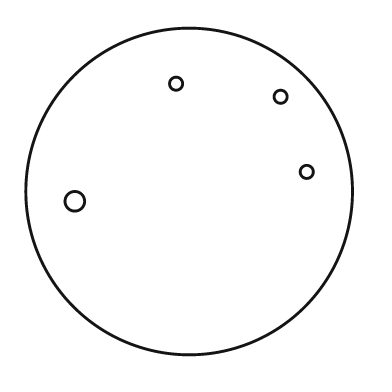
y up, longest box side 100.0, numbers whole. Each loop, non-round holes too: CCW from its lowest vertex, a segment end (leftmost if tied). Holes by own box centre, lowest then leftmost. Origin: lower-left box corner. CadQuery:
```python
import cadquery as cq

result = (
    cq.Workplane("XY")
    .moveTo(50.0, 50.0)
    .circle(50.0)
    .moveTo(15.0, 47.0)
    .circle(3.0)
    .moveTo(86.0, 56.0)
    .circle(2.0)
    .moveTo(78.0, 79.0)
    .circle(2.0)
    .moveTo(46.0, 83.0)
    .circle(2.0)
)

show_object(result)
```